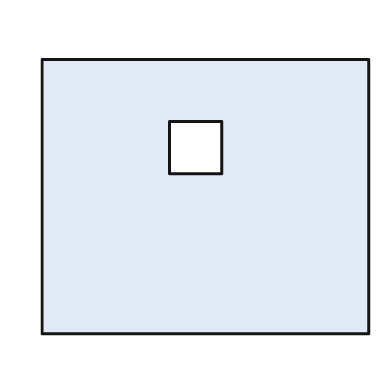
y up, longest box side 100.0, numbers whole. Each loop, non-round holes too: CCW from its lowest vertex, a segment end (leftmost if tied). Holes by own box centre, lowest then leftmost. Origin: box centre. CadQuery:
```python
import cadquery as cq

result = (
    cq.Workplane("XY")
    .moveTo(-50.0, -42.0)
    .lineTo(50.0, -42.0)
    .lineTo(50.0, 42.0)
    .lineTo(-50.0, 42.0)
    .close()
    .moveTo(-11.0, 7.0)
    .lineTo(5.0, 7.0)
    .lineTo(5.0, 23.0)
    .lineTo(-11.0, 23.0)
    .close()
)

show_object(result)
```